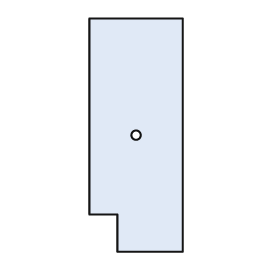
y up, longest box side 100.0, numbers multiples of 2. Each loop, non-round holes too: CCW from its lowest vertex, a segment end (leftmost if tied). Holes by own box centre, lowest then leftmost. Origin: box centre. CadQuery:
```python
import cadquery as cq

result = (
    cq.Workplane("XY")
    .moveTo(-8.0, -50.0)
    .lineTo(20.0, -50.0)
    .lineTo(20.0, 50.0)
    .lineTo(-20.0, 50.0)
    .lineTo(-20.0, -34.0)
    .lineTo(-8.0, -34.0)
    .close()
    .moveTo(0.0, 0.0)
    .circle(2.0)
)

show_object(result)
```